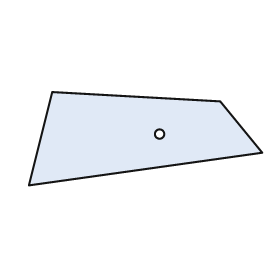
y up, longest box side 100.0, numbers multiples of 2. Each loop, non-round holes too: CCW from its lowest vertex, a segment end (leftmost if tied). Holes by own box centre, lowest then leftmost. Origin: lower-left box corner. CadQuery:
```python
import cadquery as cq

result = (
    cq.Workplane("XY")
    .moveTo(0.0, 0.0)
    .lineTo(100.0, 14.0)
    .lineTo(82.0, 36.0)
    .lineTo(10.0, 40.0)
    .close()
    .moveTo(56.0, 22.0)
    .circle(2.0)
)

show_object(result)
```